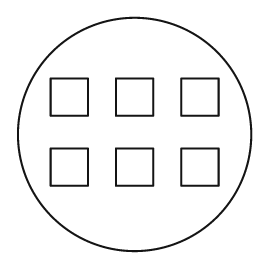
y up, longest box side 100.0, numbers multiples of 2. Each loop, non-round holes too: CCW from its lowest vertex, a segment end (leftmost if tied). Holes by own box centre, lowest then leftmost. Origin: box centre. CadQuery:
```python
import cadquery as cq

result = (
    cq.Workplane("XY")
    .moveTo(0.0, 0.0)
    .circle(50.0)
    .moveTo(-36.0, -22.0)
    .lineTo(-20.0, -22.0)
    .lineTo(-20.0, -6.0)
    .lineTo(-36.0, -6.0)
    .close()
    .moveTo(-8.0, -22.0)
    .lineTo(8.0, -22.0)
    .lineTo(8.0, -6.0)
    .lineTo(-8.0, -6.0)
    .close()
    .moveTo(20.0, -22.0)
    .lineTo(36.0, -22.0)
    .lineTo(36.0, -6.0)
    .lineTo(20.0, -6.0)
    .close()
    .moveTo(-36.0, 8.0)
    .lineTo(-20.0, 8.0)
    .lineTo(-20.0, 24.0)
    .lineTo(-36.0, 24.0)
    .close()
    .moveTo(-8.0, 8.0)
    .lineTo(8.0, 8.0)
    .lineTo(8.0, 24.0)
    .lineTo(-8.0, 24.0)
    .close()
    .moveTo(20.0, 8.0)
    .lineTo(36.0, 8.0)
    .lineTo(36.0, 24.0)
    .lineTo(20.0, 24.0)
    .close()
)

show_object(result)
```